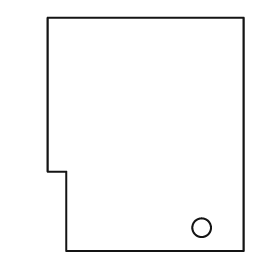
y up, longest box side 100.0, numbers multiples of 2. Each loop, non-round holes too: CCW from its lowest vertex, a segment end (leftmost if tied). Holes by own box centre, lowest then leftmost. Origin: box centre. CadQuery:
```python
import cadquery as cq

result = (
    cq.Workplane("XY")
    .moveTo(-34.0, -50.0)
    .lineTo(42.0, -50.0)
    .lineTo(42.0, 50.0)
    .lineTo(-42.0, 50.0)
    .lineTo(-42.0, -16.0)
    .lineTo(-34.0, -16.0)
    .close()
    .moveTo(24.0, -40.0)
    .circle(4.0)
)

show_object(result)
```